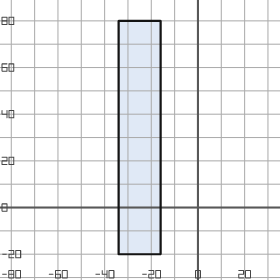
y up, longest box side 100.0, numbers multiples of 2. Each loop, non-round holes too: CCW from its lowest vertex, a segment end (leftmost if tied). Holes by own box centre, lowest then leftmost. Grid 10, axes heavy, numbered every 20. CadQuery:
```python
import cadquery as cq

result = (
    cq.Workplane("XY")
    .moveTo(-34.0, -20.0)
    .lineTo(-16.0, -20.0)
    .lineTo(-16.0, 80.0)
    .lineTo(-34.0, 80.0)
    .close()
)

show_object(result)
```